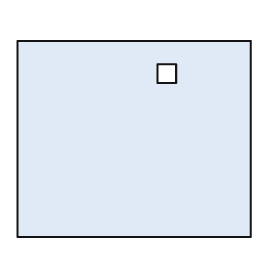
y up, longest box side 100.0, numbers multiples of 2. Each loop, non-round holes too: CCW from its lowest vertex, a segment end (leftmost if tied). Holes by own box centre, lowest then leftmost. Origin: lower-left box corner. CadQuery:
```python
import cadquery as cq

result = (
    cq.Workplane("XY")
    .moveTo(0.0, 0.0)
    .lineTo(100.0, 0.0)
    .lineTo(100.0, 84.0)
    .lineTo(0.0, 84.0)
    .close()
    .moveTo(60.0, 66.0)
    .lineTo(68.0, 66.0)
    .lineTo(68.0, 74.0)
    .lineTo(60.0, 74.0)
    .close()
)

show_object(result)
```